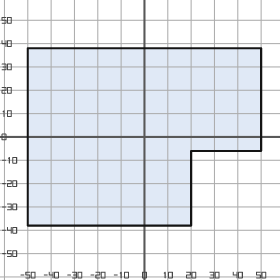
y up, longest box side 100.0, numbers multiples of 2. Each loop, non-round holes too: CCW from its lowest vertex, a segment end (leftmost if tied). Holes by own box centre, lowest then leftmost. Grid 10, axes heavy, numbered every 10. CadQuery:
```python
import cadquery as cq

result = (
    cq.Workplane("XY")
    .moveTo(-50.0, -38.0)
    .lineTo(20.0, -38.0)
    .lineTo(20.0, -6.0)
    .lineTo(50.0, -6.0)
    .lineTo(50.0, 38.0)
    .lineTo(-50.0, 38.0)
    .close()
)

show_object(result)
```